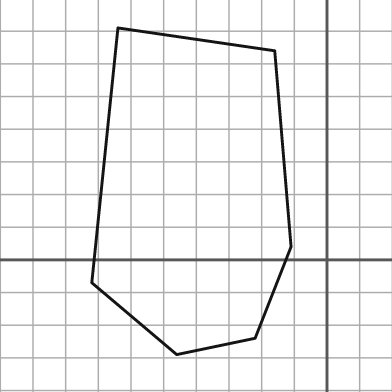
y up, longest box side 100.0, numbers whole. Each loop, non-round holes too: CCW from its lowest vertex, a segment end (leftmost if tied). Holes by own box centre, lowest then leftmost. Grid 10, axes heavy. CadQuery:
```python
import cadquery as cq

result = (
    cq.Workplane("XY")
    .moveTo(-46.0, -29.0)
    .lineTo(-22.0, -24.0)
    .lineTo(-11.0, 4.0)
    .lineTo(-16.0, 64.0)
    .lineTo(-64.0, 71.0)
    .lineTo(-72.0, -7.0)
    .close()
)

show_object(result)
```